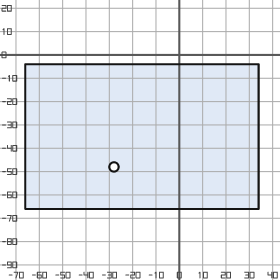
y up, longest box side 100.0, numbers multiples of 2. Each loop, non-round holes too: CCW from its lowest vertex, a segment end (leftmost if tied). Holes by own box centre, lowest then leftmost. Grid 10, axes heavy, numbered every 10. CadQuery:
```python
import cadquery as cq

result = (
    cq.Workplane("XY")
    .moveTo(-66.0, -66.0)
    .lineTo(34.0, -66.0)
    .lineTo(34.0, -4.0)
    .lineTo(-66.0, -4.0)
    .close()
    .moveTo(-28.0, -48.0)
    .circle(2.0)
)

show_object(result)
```